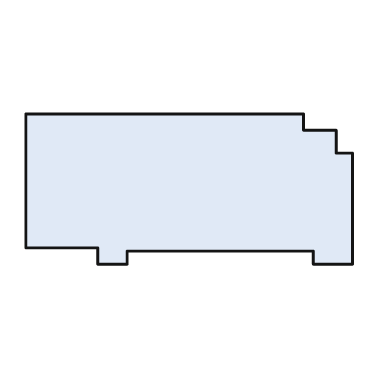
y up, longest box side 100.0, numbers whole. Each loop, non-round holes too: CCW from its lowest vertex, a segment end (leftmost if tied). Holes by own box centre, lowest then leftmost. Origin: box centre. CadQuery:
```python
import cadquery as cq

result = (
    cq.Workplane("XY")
    .moveTo(-28.0, -23.0)
    .lineTo(-19.0, -23.0)
    .lineTo(-19.0, -19.0)
    .lineTo(38.0, -19.0)
    .lineTo(38.0, -23.0)
    .lineTo(50.0, -23.0)
    .lineTo(50.0, 11.0)
    .lineTo(45.0, 11.0)
    .lineTo(45.0, 18.0)
    .lineTo(35.0, 18.0)
    .lineTo(35.0, 23.0)
    .lineTo(-50.0, 23.0)
    .lineTo(-50.0, -18.0)
    .lineTo(-28.0, -18.0)
    .close()
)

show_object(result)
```